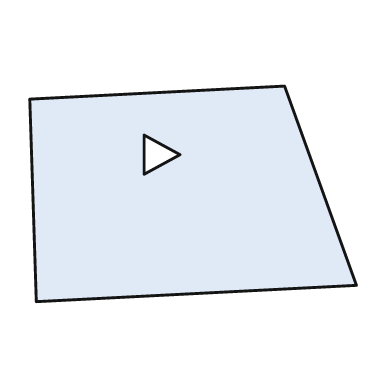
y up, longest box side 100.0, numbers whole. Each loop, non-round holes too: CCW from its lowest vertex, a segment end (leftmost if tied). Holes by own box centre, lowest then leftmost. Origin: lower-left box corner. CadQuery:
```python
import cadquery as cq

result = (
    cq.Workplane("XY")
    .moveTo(2.0, 0.0)
    .lineTo(100.0, 5.0)
    .lineTo(78.0, 66.0)
    .lineTo(0.0, 62.0)
    .close()
    .moveTo(35.0, 39.0)
    .lineTo(46.0, 45.0)
    .lineTo(35.0, 51.0)
    .close()
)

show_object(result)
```